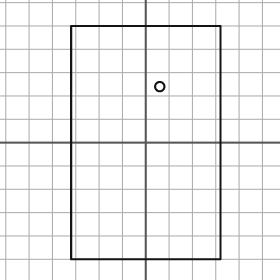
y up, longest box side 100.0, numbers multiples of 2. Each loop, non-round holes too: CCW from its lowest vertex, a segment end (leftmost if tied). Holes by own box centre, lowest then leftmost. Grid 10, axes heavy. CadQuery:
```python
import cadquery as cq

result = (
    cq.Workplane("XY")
    .moveTo(-32.0, -50.0)
    .lineTo(32.0, -50.0)
    .lineTo(32.0, 50.0)
    .lineTo(-32.0, 50.0)
    .close()
    .moveTo(6.0, 24.0)
    .circle(2.0)
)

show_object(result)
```